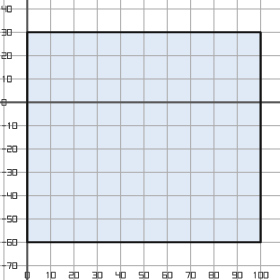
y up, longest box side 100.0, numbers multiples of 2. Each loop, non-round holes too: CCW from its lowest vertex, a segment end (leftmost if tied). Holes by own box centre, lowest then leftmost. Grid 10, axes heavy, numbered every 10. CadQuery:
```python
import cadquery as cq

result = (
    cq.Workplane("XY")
    .moveTo(0.0, -60.0)
    .lineTo(100.0, -60.0)
    .lineTo(100.0, 30.0)
    .lineTo(0.0, 30.0)
    .close()
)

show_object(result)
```